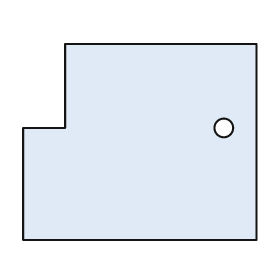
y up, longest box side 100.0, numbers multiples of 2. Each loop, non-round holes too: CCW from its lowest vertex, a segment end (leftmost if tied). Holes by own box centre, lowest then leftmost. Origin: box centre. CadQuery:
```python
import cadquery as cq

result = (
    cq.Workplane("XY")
    .moveTo(-50.0, -42.0)
    .lineTo(50.0, -42.0)
    .lineTo(50.0, 42.0)
    .lineTo(-32.0, 42.0)
    .lineTo(-32.0, 6.0)
    .lineTo(-50.0, 6.0)
    .close()
    .moveTo(36.0, 6.0)
    .circle(4.0)
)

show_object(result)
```